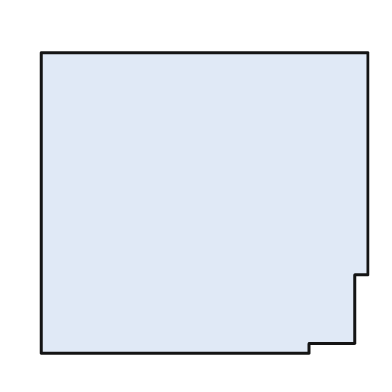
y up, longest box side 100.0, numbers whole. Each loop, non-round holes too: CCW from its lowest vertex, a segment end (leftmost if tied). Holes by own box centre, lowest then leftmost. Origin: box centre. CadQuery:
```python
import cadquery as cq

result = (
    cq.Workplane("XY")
    .moveTo(-50.0, -46.0)
    .lineTo(32.0, -46.0)
    .lineTo(32.0, -43.0)
    .lineTo(46.0, -43.0)
    .lineTo(46.0, -22.0)
    .lineTo(50.0, -22.0)
    .lineTo(50.0, 46.0)
    .lineTo(-50.0, 46.0)
    .close()
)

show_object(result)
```